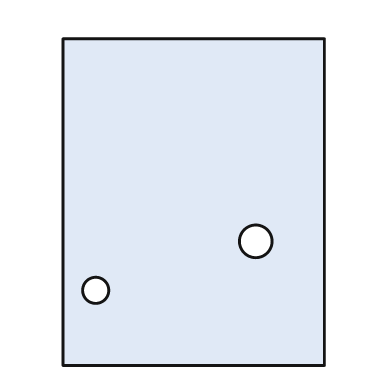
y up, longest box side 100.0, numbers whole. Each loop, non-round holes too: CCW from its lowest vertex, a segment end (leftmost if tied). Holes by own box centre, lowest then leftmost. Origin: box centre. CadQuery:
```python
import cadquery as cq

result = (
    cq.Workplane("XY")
    .moveTo(-40.0, -50.0)
    .lineTo(40.0, -50.0)
    .lineTo(40.0, 50.0)
    .lineTo(-40.0, 50.0)
    .close()
    .moveTo(-30.0, -27.0)
    .circle(4.0)
    .moveTo(19.0, -12.0)
    .circle(5.0)
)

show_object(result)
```